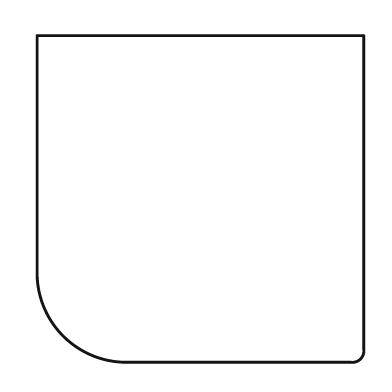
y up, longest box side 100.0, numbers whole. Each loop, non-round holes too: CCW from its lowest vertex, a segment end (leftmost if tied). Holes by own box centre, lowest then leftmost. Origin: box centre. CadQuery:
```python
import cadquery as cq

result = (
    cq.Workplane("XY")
    .moveTo(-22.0, -50.0)
    .lineTo(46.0, -50.0)
    .threePointArc((49.0, -49.0), (50.0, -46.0))
    .lineTo(50.0, 50.0)
    .lineTo(-50.0, 50.0)
    .lineTo(-50.0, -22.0)
    .threePointArc((-42.0, -42.0), (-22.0, -50.0))
    .close()
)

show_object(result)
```